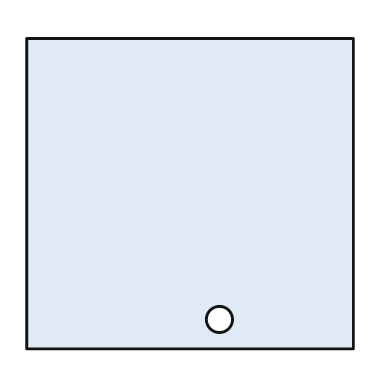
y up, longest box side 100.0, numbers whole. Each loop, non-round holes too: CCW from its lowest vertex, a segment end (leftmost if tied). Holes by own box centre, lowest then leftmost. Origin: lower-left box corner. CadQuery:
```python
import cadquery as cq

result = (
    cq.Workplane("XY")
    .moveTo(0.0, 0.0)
    .lineTo(100.0, 0.0)
    .lineTo(100.0, 95.0)
    .lineTo(0.0, 95.0)
    .close()
    .moveTo(59.0, 9.0)
    .circle(4.0)
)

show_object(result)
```